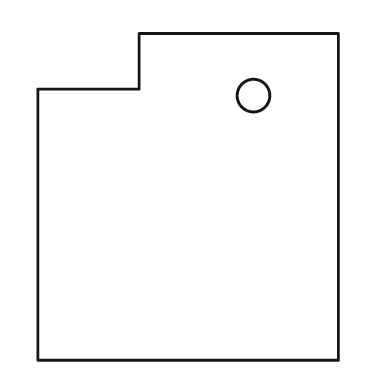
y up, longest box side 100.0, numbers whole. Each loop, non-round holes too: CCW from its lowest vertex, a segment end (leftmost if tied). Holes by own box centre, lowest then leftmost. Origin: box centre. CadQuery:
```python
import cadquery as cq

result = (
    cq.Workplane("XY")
    .moveTo(-46.0, -50.0)
    .lineTo(46.0, -50.0)
    .lineTo(46.0, 50.0)
    .lineTo(-15.0, 50.0)
    .lineTo(-15.0, 33.0)
    .lineTo(-46.0, 33.0)
    .close()
    .moveTo(20.0, 31.0)
    .circle(5.0)
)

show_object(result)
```